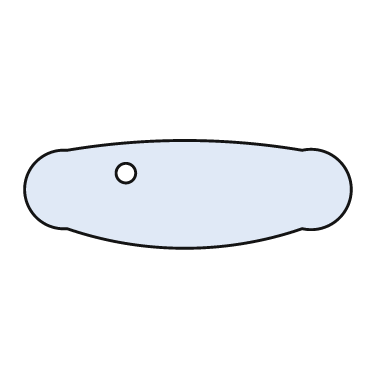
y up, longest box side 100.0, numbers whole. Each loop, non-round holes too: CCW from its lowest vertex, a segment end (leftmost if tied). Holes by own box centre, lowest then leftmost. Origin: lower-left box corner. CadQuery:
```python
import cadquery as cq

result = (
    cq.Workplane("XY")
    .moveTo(13.0, 6.0)
    .threePointArc((49.0, 0.0), (85.0, 6.0))
    .threePointArc((100.0, 18.0), (85.0, 30.0))
    .threePointArc((49.0, 33.0), (13.0, 30.0))
    .threePointArc((0.0, 18.0), (13.0, 6.0))
    .close()
    .moveTo(31.0, 23.0)
    .circle(3.0)
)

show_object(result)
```